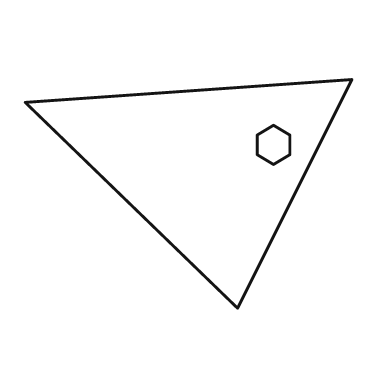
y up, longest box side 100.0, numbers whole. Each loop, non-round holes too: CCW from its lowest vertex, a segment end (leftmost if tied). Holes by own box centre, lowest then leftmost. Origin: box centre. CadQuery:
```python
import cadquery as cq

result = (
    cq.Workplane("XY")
    .moveTo(15.0, -35.0)
    .lineTo(50.0, 35.0)
    .lineTo(-50.0, 28.0)
    .close()
    .moveTo(26.0, 9.0)
    .lineTo(31.0, 12.0)
    .lineTo(31.0, 18.0)
    .lineTo(26.0, 21.0)
    .lineTo(21.0, 18.0)
    .lineTo(21.0, 12.0)
    .close()
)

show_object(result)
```